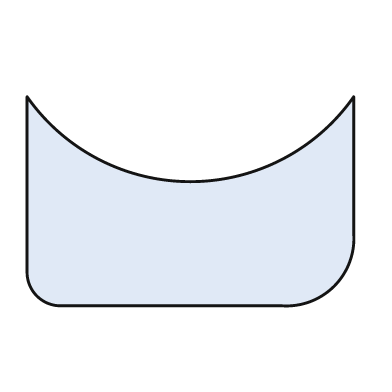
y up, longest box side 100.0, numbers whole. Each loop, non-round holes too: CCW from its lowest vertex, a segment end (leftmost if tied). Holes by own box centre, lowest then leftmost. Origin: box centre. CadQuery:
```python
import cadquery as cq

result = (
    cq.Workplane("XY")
    .moveTo(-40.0, -32.0)
    .lineTo(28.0, -32.0)
    .threePointArc((44.0, -26.0), (50.0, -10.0))
    .lineTo(50.0, 32.0)
    .threePointArc((0.0, 6.0), (-50.0, 32.0))
    .lineTo(-50.0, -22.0)
    .threePointArc((-47.0, -29.0), (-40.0, -32.0))
    .close()
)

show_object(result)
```